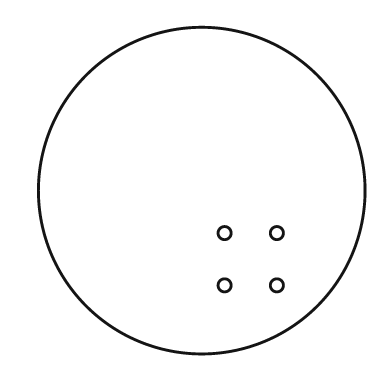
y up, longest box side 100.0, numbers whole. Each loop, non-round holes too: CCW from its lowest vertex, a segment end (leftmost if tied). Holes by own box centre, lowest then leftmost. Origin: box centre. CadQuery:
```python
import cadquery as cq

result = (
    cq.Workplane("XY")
    .moveTo(0.0, 0.0)
    .circle(50.0)
    .moveTo(7.0, -29.0)
    .circle(2.0)
    .moveTo(23.0, -29.0)
    .circle(2.0)
    .moveTo(7.0, -13.0)
    .circle(2.0)
    .moveTo(23.0, -13.0)
    .circle(2.0)
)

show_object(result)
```